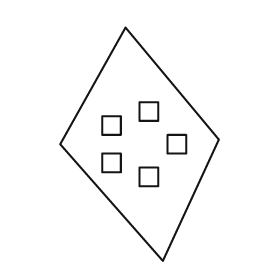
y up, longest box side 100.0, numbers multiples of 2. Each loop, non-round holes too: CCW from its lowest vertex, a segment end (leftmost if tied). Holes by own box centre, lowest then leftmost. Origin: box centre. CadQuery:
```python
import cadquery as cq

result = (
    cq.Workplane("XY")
    .moveTo(10.0, -50.0)
    .lineTo(34.0, 2.0)
    .lineTo(-6.0, 50.0)
    .lineTo(-34.0, 0.0)
    .close()
    .moveTo(0.0, -18.0)
    .lineTo(8.0, -18.0)
    .lineTo(8.0, -10.0)
    .lineTo(0.0, -10.0)
    .close()
    .moveTo(-16.0, -12.0)
    .lineTo(-8.0, -12.0)
    .lineTo(-8.0, -4.0)
    .lineTo(-16.0, -4.0)
    .close()
    .moveTo(12.0, -4.0)
    .lineTo(20.0, -4.0)
    .lineTo(20.0, 4.0)
    .lineTo(12.0, 4.0)
    .close()
    .moveTo(-16.0, 4.0)
    .lineTo(-8.0, 4.0)
    .lineTo(-8.0, 12.0)
    .lineTo(-16.0, 12.0)
    .close()
    .moveTo(0.0, 10.0)
    .lineTo(8.0, 10.0)
    .lineTo(8.0, 18.0)
    .lineTo(0.0, 18.0)
    .close()
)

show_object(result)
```